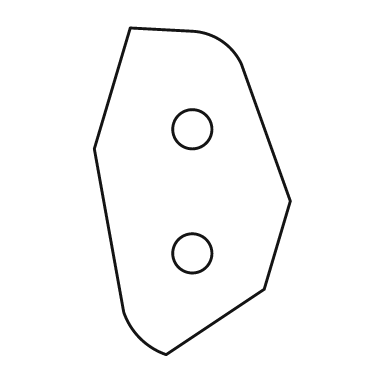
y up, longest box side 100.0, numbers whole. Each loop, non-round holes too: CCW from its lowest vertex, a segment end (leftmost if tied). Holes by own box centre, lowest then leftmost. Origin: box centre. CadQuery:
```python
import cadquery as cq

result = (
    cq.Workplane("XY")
    .moveTo(-8.0, -50.0)
    .lineTo(22.0, -30.0)
    .lineTo(30.0, -3.0)
    .lineTo(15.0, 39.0)
    .threePointArc((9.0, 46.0), (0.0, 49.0))
    .lineTo(-19.0, 50.0)
    .lineTo(-30.0, 13.0)
    .lineTo(-21.0, -37.0)
    .threePointArc((-16.0, -45.0), (-8.0, -50.0))
    .close()
    .moveTo(0.0, -19.0)
    .circle(6.0)
    .moveTo(0.0, 19.0)
    .circle(6.0)
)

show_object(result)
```